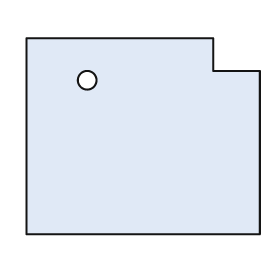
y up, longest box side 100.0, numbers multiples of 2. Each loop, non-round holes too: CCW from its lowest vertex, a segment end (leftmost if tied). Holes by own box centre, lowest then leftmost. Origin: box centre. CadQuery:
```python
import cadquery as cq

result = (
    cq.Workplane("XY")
    .moveTo(-50.0, -42.0)
    .lineTo(50.0, -42.0)
    .lineTo(50.0, 28.0)
    .lineTo(30.0, 28.0)
    .lineTo(30.0, 42.0)
    .lineTo(-50.0, 42.0)
    .close()
    .moveTo(-24.0, 24.0)
    .circle(4.0)
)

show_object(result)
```